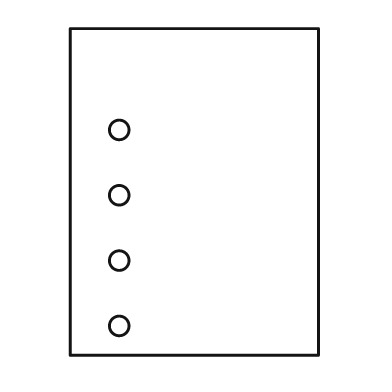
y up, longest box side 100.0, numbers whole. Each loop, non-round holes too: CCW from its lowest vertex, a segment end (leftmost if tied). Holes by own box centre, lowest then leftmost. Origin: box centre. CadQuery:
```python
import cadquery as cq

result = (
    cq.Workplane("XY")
    .moveTo(-38.0, -50.0)
    .lineTo(38.0, -50.0)
    .lineTo(38.0, 50.0)
    .lineTo(-38.0, 50.0)
    .close()
    .moveTo(-23.0, -41.0)
    .circle(3.0)
    .moveTo(-23.0, -21.0)
    .circle(3.0)
    .moveTo(-23.0, -1.0)
    .circle(3.0)
    .moveTo(-23.0, 19.0)
    .circle(3.0)
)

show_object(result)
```